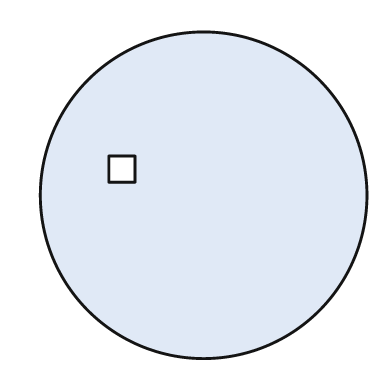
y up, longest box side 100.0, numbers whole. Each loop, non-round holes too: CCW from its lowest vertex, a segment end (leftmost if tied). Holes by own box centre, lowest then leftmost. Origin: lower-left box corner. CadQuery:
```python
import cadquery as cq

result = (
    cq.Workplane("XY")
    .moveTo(50.0, 50.0)
    .circle(50.0)
    .moveTo(21.0, 54.0)
    .lineTo(29.0, 54.0)
    .lineTo(29.0, 62.0)
    .lineTo(21.0, 62.0)
    .close()
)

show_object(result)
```